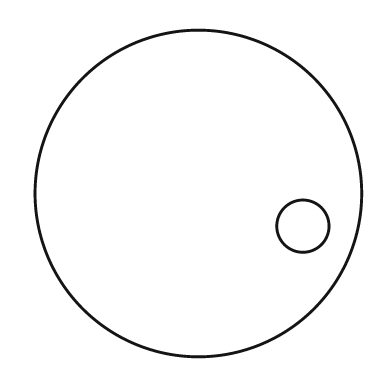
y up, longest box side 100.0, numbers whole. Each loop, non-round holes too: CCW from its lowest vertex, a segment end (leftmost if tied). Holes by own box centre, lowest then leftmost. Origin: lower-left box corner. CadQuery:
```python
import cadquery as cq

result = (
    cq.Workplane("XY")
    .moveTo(50.0, 50.0)
    .circle(50.0)
    .moveTo(82.0, 40.0)
    .circle(8.0)
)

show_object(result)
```